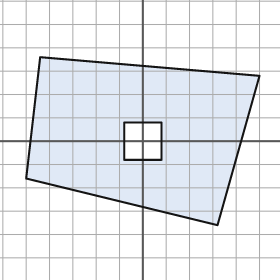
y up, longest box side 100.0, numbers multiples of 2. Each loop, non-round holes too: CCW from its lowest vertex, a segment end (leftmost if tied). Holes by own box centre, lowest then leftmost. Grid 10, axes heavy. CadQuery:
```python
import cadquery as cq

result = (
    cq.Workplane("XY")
    .moveTo(32.0, -36.0)
    .lineTo(50.0, 28.0)
    .lineTo(-44.0, 36.0)
    .lineTo(-50.0, -16.0)
    .close()
    .moveTo(-8.0, -8.0)
    .lineTo(8.0, -8.0)
    .lineTo(8.0, 8.0)
    .lineTo(-8.0, 8.0)
    .close()
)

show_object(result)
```